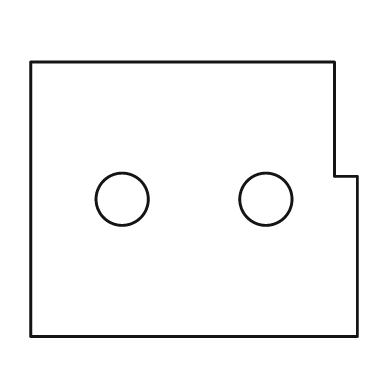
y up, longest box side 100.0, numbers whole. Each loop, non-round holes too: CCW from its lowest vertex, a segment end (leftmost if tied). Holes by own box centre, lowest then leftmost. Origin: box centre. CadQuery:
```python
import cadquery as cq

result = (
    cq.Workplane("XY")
    .moveTo(-50.0, -42.0)
    .lineTo(50.0, -42.0)
    .lineTo(50.0, 7.0)
    .lineTo(43.0, 7.0)
    .lineTo(43.0, 42.0)
    .lineTo(-50.0, 42.0)
    .close()
    .moveTo(-22.0, 0.0)
    .circle(8.0)
    .moveTo(22.0, 0.0)
    .circle(8.0)
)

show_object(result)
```